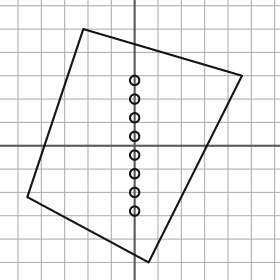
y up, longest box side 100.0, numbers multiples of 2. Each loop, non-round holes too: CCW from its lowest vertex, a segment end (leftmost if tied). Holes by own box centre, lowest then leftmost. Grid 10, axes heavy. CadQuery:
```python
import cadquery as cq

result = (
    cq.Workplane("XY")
    .moveTo(6.0, -50.0)
    .lineTo(46.0, 30.0)
    .lineTo(-22.0, 50.0)
    .lineTo(-46.0, -22.0)
    .close()
    .moveTo(0.0, -28.0)
    .circle(2.0)
    .moveTo(0.0, -20.0)
    .circle(2.0)
    .moveTo(0.0, -12.0)
    .circle(2.0)
    .moveTo(0.0, -4.0)
    .circle(2.0)
    .moveTo(0.0, 4.0)
    .circle(2.0)
    .moveTo(0.0, 12.0)
    .circle(2.0)
    .moveTo(0.0, 20.0)
    .circle(2.0)
    .moveTo(0.0, 28.0)
    .circle(2.0)
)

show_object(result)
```